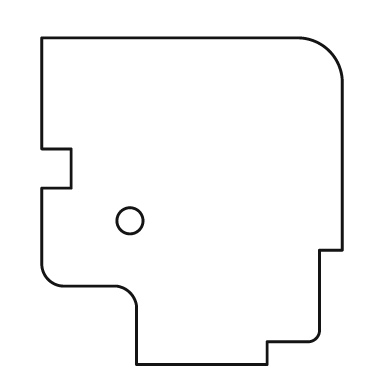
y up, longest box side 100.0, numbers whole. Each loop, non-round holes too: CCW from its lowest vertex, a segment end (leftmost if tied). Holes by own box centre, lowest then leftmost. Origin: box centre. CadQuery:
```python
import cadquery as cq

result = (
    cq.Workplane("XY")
    .moveTo(-17.0, -50.0)
    .lineTo(23.0, -50.0)
    .lineTo(23.0, -43.0)
    .lineTo(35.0, -43.0)
    .threePointArc((38.0, -42.0), (39.0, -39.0))
    .lineTo(39.0, -15.0)
    .lineTo(46.0, -15.0)
    .lineTo(46.0, 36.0)
    .threePointArc((42.0, 46.0), (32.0, 50.0))
    .lineTo(-46.0, 50.0)
    .lineTo(-46.0, 16.0)
    .lineTo(-37.0, 16.0)
    .lineTo(-37.0, 4.0)
    .lineTo(-46.0, 4.0)
    .lineTo(-46.0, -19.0)
    .threePointArc((-44.0, -24.0), (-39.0, -26.0))
    .lineTo(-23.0, -26.0)
    .threePointArc((-19.0, -28.0), (-17.0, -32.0))
    .close()
    .moveTo(-19.0, -6.0)
    .circle(4.0)
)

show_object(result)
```